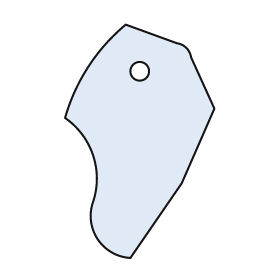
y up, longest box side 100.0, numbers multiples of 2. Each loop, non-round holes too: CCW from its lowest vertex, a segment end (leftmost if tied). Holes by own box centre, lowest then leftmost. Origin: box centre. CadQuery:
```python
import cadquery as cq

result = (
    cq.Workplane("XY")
    .moveTo(-4.0, -50.0)
    .lineTo(18.0, -18.0)
    .lineTo(32.0, 14.0)
    .lineTo(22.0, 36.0)
    .threePointArc((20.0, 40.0), (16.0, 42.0))
    .lineTo(-6.0, 50.0)
    .threePointArc((-22.0, 32.0), (-32.0, 10.0))
    .threePointArc((-20.0, -6.0), (-20.0, -26.0))
    .threePointArc((-18.0, -42.0), (-4.0, -50.0))
    .close()
    .moveTo(0.0, 30.0)
    .circle(4.0)
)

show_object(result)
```